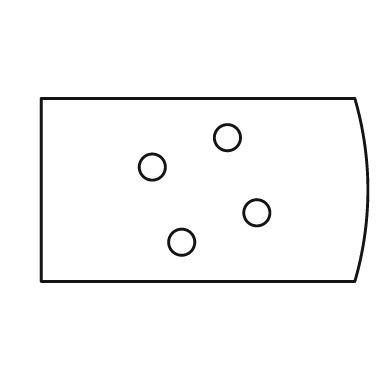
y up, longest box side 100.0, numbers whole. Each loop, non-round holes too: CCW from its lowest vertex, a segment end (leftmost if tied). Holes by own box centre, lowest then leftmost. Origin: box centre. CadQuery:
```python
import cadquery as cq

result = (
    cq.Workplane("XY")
    .moveTo(-50.0, -28.0)
    .lineTo(46.0, -28.0)
    .threePointArc((50.0, 0.0), (46.0, 28.0))
    .lineTo(-50.0, 28.0)
    .close()
    .moveTo(-7.0, -16.0)
    .circle(4.0)
    .moveTo(16.0, -7.0)
    .circle(4.0)
    .moveTo(-16.0, 7.0)
    .circle(4.0)
    .moveTo(7.0, 16.0)
    .circle(4.0)
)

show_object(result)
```